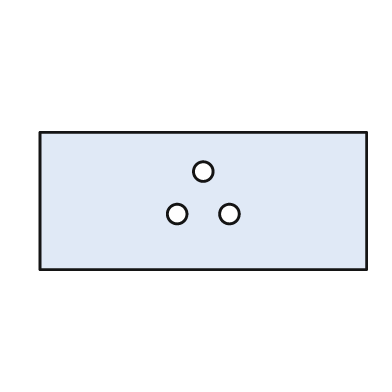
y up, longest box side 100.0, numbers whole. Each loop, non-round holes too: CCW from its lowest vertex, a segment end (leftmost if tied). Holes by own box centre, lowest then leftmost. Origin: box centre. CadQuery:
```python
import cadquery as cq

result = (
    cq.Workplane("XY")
    .moveTo(-50.0, -21.0)
    .lineTo(50.0, -21.0)
    .lineTo(50.0, 21.0)
    .lineTo(-50.0, 21.0)
    .close()
    .moveTo(-8.0, -4.0)
    .circle(3.0)
    .moveTo(8.0, -4.0)
    .circle(3.0)
    .moveTo(0.0, 9.0)
    .circle(3.0)
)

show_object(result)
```